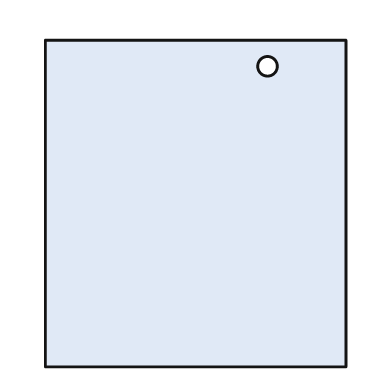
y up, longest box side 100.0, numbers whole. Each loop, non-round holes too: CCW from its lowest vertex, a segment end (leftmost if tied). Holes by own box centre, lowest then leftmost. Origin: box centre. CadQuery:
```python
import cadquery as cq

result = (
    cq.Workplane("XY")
    .moveTo(-46.0, -50.0)
    .lineTo(46.0, -50.0)
    .lineTo(46.0, 50.0)
    .lineTo(-46.0, 50.0)
    .close()
    .moveTo(22.0, 42.0)
    .circle(3.0)
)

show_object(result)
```